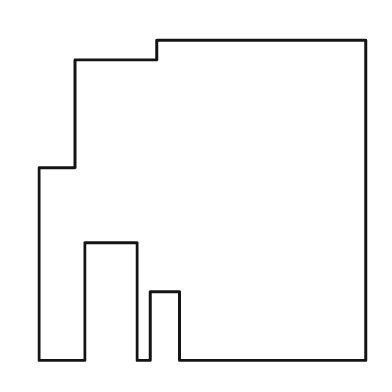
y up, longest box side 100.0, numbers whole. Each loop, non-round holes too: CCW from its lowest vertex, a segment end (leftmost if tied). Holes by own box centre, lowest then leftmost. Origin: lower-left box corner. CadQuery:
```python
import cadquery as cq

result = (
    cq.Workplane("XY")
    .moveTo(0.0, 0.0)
    .lineTo(14.0, 0.0)
    .lineTo(14.0, 36.0)
    .lineTo(30.0, 36.0)
    .lineTo(30.0, 0.0)
    .lineTo(34.0, 0.0)
    .lineTo(34.0, 21.0)
    .lineTo(43.0, 21.0)
    .lineTo(43.0, 0.0)
    .lineTo(100.0, 0.0)
    .lineTo(100.0, 98.0)
    .lineTo(36.0, 98.0)
    .lineTo(36.0, 92.0)
    .lineTo(11.0, 92.0)
    .lineTo(11.0, 59.0)
    .lineTo(0.0, 59.0)
    .close()
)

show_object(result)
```